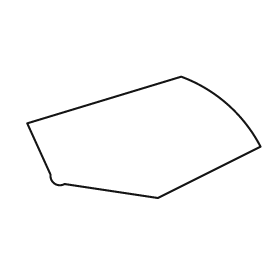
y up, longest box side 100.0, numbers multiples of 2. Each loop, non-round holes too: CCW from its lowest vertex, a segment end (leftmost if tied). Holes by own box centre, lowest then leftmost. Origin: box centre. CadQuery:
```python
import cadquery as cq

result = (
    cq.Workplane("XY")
    .moveTo(6.0, -26.0)
    .lineTo(50.0, -4.0)
    .threePointArc((36.0, 14.0), (16.0, 26.0))
    .lineTo(-50.0, 6.0)
    .lineTo(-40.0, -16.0)
    .threePointArc((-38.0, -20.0), (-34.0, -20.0))
    .close()
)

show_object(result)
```